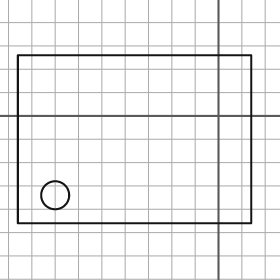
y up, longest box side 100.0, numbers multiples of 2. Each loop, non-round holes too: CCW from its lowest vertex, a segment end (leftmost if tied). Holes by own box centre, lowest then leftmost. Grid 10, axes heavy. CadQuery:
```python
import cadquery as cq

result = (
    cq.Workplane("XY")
    .moveTo(-86.0, -46.0)
    .lineTo(14.0, -46.0)
    .lineTo(14.0, 26.0)
    .lineTo(-86.0, 26.0)
    .close()
    .moveTo(-70.0, -34.0)
    .circle(6.0)
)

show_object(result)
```